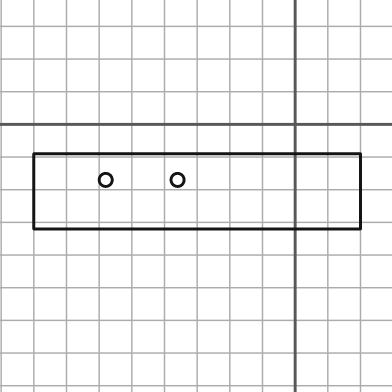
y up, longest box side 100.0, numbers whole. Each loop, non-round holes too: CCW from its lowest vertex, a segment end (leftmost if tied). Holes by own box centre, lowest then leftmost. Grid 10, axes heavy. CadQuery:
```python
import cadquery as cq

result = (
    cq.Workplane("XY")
    .moveTo(-80.0, -32.0)
    .lineTo(20.0, -32.0)
    .lineTo(20.0, -9.0)
    .lineTo(-80.0, -9.0)
    .close()
    .moveTo(-58.0, -17.0)
    .circle(2.0)
    .moveTo(-36.0, -17.0)
    .circle(2.0)
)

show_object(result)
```